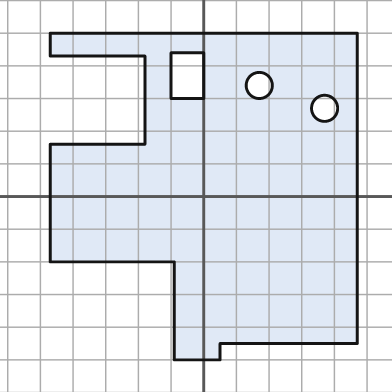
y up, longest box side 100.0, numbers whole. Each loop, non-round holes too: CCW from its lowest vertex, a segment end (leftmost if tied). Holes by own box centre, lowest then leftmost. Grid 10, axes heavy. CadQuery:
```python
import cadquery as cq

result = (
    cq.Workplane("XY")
    .moveTo(-9.0, -50.0)
    .lineTo(5.0, -50.0)
    .lineTo(5.0, -45.0)
    .lineTo(47.0, -45.0)
    .lineTo(47.0, 50.0)
    .lineTo(-47.0, 50.0)
    .lineTo(-47.0, 43.0)
    .lineTo(-18.0, 43.0)
    .lineTo(-18.0, 16.0)
    .lineTo(-47.0, 16.0)
    .lineTo(-47.0, -20.0)
    .lineTo(-9.0, -20.0)
    .close()
    .moveTo(37.0, 27.0)
    .circle(4.0)
    .moveTo(17.0, 34.0)
    .circle(4.0)
    .moveTo(-10.0, 30.0)
    .lineTo(0.0, 30.0)
    .lineTo(0.0, 44.0)
    .lineTo(-10.0, 44.0)
    .close()
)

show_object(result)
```